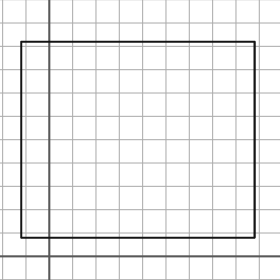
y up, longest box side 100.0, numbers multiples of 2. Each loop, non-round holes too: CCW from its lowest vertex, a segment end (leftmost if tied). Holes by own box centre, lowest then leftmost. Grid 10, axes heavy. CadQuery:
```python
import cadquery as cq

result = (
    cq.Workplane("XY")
    .moveTo(-12.0, 8.0)
    .lineTo(88.0, 8.0)
    .lineTo(88.0, 92.0)
    .lineTo(-12.0, 92.0)
    .close()
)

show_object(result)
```